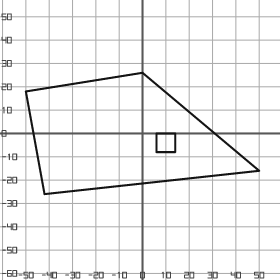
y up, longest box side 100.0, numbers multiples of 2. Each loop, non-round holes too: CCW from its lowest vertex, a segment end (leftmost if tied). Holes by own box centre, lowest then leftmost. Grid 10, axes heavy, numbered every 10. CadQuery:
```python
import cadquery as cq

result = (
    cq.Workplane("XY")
    .moveTo(-42.0, -26.0)
    .lineTo(50.0, -16.0)
    .lineTo(0.0, 26.0)
    .lineTo(-50.0, 18.0)
    .close()
    .moveTo(6.0, -8.0)
    .lineTo(14.0, -8.0)
    .lineTo(14.0, 0.0)
    .lineTo(6.0, 0.0)
    .close()
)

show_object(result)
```